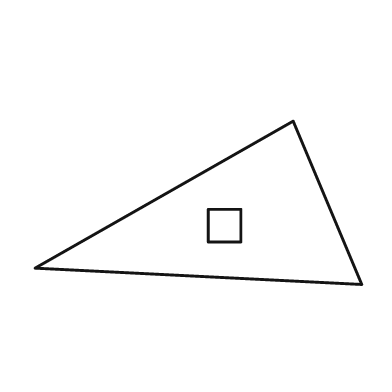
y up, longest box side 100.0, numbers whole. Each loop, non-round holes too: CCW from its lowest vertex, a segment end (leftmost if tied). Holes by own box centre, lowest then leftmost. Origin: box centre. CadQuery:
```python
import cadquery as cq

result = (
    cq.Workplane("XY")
    .moveTo(50.0, -25.0)
    .lineTo(29.0, 25.0)
    .lineTo(-50.0, -20.0)
    .close()
    .moveTo(3.0, -12.0)
    .lineTo(13.0, -12.0)
    .lineTo(13.0, -2.0)
    .lineTo(3.0, -2.0)
    .close()
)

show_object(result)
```